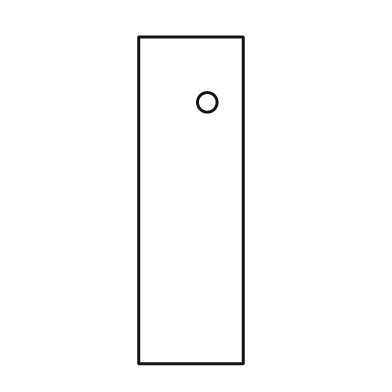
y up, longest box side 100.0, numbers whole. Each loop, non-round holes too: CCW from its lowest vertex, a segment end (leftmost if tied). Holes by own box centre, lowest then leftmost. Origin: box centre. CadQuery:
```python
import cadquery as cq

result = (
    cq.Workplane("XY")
    .moveTo(-16.0, -50.0)
    .lineTo(16.0, -50.0)
    .lineTo(16.0, 50.0)
    .lineTo(-16.0, 50.0)
    .close()
    .moveTo(5.0, 30.0)
    .circle(3.0)
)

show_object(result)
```